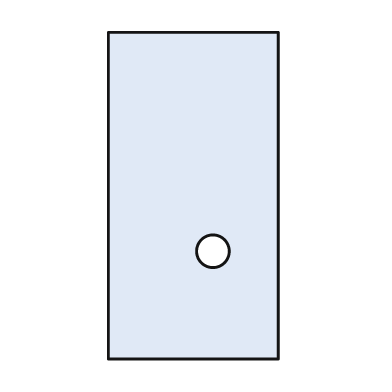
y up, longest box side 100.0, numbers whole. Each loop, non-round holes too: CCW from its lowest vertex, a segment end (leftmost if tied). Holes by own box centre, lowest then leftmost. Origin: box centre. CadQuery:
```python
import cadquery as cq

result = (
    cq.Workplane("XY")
    .moveTo(-26.0, -50.0)
    .lineTo(26.0, -50.0)
    .lineTo(26.0, 50.0)
    .lineTo(-26.0, 50.0)
    .close()
    .moveTo(6.0, -17.0)
    .circle(5.0)
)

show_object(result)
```